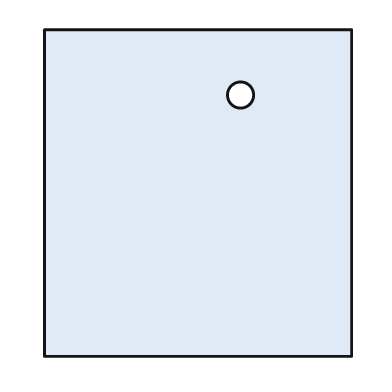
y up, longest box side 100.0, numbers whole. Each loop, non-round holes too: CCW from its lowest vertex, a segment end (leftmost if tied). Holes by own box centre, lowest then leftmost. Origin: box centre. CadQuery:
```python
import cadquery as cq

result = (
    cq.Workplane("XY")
    .moveTo(-47.0, -50.0)
    .lineTo(47.0, -50.0)
    .lineTo(47.0, 50.0)
    .lineTo(-47.0, 50.0)
    .close()
    .moveTo(13.0, 30.0)
    .circle(4.0)
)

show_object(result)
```